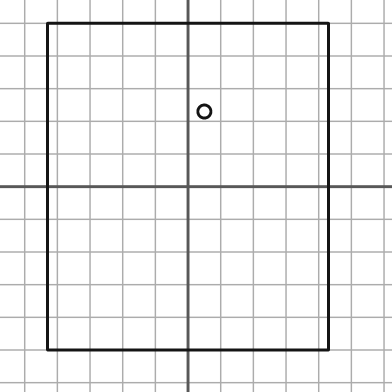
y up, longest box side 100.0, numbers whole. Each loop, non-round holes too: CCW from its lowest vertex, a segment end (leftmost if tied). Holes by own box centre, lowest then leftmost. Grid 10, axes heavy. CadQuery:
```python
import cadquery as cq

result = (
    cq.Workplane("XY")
    .moveTo(-43.0, -50.0)
    .lineTo(43.0, -50.0)
    .lineTo(43.0, 50.0)
    .lineTo(-43.0, 50.0)
    .close()
    .moveTo(5.0, 23.0)
    .circle(2.0)
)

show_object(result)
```